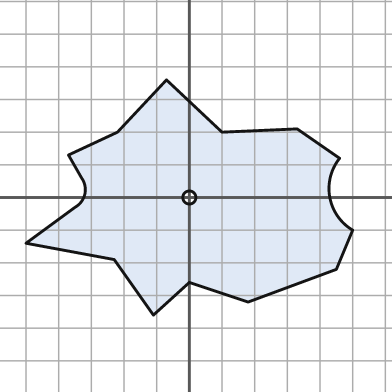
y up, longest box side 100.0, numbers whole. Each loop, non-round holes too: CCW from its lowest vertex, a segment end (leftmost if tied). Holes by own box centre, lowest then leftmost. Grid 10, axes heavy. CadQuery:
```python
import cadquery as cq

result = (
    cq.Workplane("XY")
    .moveTo(-11.0, -36.0)
    .lineTo(0.0, -26.0)
    .lineTo(18.0, -32.0)
    .lineTo(45.0, -22.0)
    .lineTo(50.0, -10.0)
    .threePointArc((43.0, 0.0), (46.0, 12.0))
    .lineTo(33.0, 21.0)
    .lineTo(10.0, 20.0)
    .lineTo(-7.0, 36.0)
    .lineTo(-22.0, 20.0)
    .lineTo(-37.0, 13.0)
    .lineTo(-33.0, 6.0)
    .threePointArc((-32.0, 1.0), (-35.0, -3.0))
    .lineTo(-50.0, -14.0)
    .lineTo(-23.0, -19.0)
    .close()
    .moveTo(0.0, 0.0)
    .circle(2.0)
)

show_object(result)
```